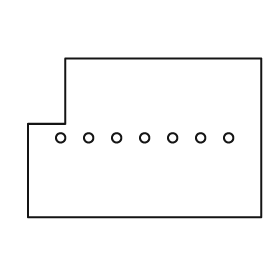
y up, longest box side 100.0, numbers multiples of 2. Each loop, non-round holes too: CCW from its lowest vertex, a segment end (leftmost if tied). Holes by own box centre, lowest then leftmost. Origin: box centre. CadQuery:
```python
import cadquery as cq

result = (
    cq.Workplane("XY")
    .moveTo(-50.0, -34.0)
    .lineTo(50.0, -34.0)
    .lineTo(50.0, 34.0)
    .lineTo(-34.0, 34.0)
    .lineTo(-34.0, 6.0)
    .lineTo(-50.0, 6.0)
    .close()
    .moveTo(-36.0, 0.0)
    .circle(2.0)
    .moveTo(-24.0, 0.0)
    .circle(2.0)
    .moveTo(-12.0, 0.0)
    .circle(2.0)
    .moveTo(0.0, 0.0)
    .circle(2.0)
    .moveTo(12.0, 0.0)
    .circle(2.0)
    .moveTo(24.0, 0.0)
    .circle(2.0)
    .moveTo(36.0, 0.0)
    .circle(2.0)
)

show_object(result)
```